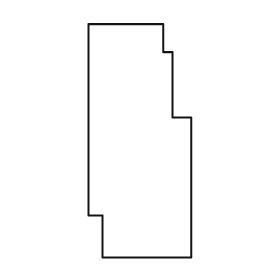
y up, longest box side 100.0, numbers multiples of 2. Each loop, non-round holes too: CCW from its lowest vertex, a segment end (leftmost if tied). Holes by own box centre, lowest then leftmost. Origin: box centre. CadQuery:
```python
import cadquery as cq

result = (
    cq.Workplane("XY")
    .moveTo(-16.0, -50.0)
    .lineTo(22.0, -50.0)
    .lineTo(22.0, 10.0)
    .lineTo(14.0, 10.0)
    .lineTo(14.0, 38.0)
    .lineTo(10.0, 38.0)
    .lineTo(10.0, 50.0)
    .lineTo(-22.0, 50.0)
    .lineTo(-22.0, -32.0)
    .lineTo(-16.0, -32.0)
    .close()
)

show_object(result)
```